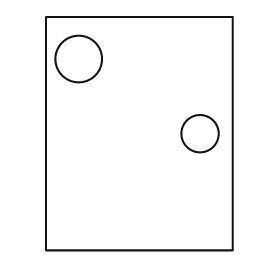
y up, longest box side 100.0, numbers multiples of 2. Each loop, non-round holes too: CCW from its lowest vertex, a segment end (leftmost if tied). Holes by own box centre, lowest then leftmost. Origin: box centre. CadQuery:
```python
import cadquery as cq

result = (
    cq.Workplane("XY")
    .moveTo(-40.0, -50.0)
    .lineTo(40.0, -50.0)
    .lineTo(40.0, 50.0)
    .lineTo(-40.0, 50.0)
    .close()
    .moveTo(26.0, 0.0)
    .circle(8.0)
    .moveTo(-26.0, 32.0)
    .circle(10.0)
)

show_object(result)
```